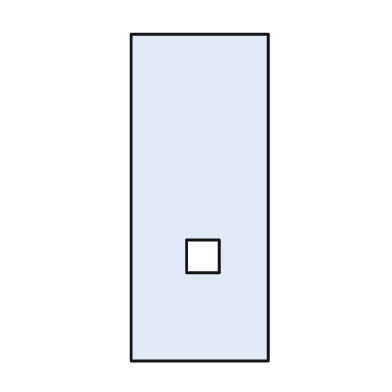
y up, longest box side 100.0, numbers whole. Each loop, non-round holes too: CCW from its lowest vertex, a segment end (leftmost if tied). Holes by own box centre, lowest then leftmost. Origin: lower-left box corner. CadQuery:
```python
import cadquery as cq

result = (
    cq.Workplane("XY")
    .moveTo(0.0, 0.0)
    .lineTo(42.0, 0.0)
    .lineTo(42.0, 100.0)
    .lineTo(0.0, 100.0)
    .close()
    .moveTo(17.0, 27.0)
    .lineTo(27.0, 27.0)
    .lineTo(27.0, 37.0)
    .lineTo(17.0, 37.0)
    .close()
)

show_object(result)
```